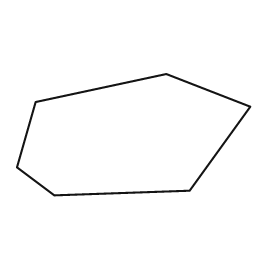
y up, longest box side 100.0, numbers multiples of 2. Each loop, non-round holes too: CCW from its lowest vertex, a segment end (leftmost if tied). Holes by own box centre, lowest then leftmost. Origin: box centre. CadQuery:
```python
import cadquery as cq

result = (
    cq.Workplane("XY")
    .moveTo(-34.0, -26.0)
    .lineTo(24.0, -24.0)
    .lineTo(50.0, 12.0)
    .lineTo(14.0, 26.0)
    .lineTo(-42.0, 14.0)
    .lineTo(-50.0, -14.0)
    .close()
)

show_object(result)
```